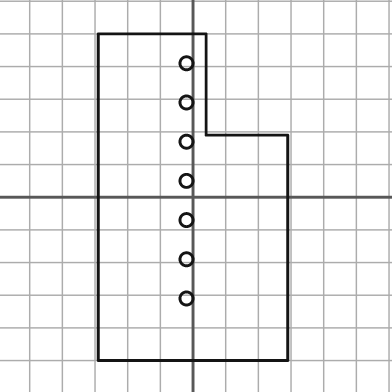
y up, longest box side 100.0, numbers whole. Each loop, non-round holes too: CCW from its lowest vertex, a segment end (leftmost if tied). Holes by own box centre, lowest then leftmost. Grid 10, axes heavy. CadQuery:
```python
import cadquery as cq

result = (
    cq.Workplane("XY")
    .moveTo(-29.0, -50.0)
    .lineTo(29.0, -50.0)
    .lineTo(29.0, 19.0)
    .lineTo(4.0, 19.0)
    .lineTo(4.0, 50.0)
    .lineTo(-29.0, 50.0)
    .close()
    .moveTo(-2.0, -31.0)
    .circle(2.0)
    .moveTo(-2.0, -19.0)
    .circle(2.0)
    .moveTo(-2.0, -7.0)
    .circle(2.0)
    .moveTo(-2.0, 5.0)
    .circle(2.0)
    .moveTo(-2.0, 17.0)
    .circle(2.0)
    .moveTo(-2.0, 29.0)
    .circle(2.0)
    .moveTo(-2.0, 41.0)
    .circle(2.0)
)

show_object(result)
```